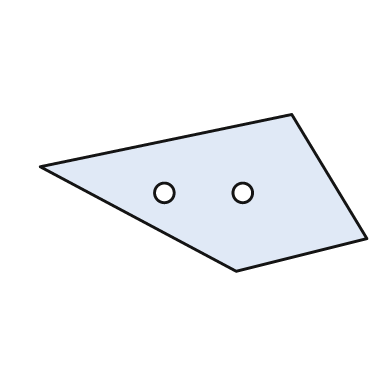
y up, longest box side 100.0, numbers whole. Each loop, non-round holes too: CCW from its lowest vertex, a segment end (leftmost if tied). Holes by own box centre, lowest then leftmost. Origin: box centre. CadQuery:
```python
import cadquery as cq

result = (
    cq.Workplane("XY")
    .moveTo(10.0, -24.0)
    .lineTo(50.0, -14.0)
    .lineTo(27.0, 24.0)
    .lineTo(-50.0, 8.0)
    .close()
    .moveTo(-12.0, 0.0)
    .circle(3.0)
    .moveTo(12.0, 0.0)
    .circle(3.0)
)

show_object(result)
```